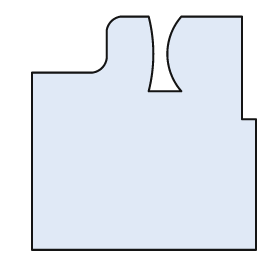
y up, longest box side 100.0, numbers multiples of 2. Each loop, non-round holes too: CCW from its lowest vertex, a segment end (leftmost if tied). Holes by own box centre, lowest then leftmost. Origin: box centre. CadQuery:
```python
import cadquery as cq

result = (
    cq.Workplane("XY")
    .moveTo(-48.0, -50.0)
    .lineTo(48.0, -50.0)
    .lineTo(48.0, 6.0)
    .lineTo(42.0, 6.0)
    .lineTo(42.0, 50.0)
    .lineTo(16.0, 50.0)
    .threePointArc((10.0, 34.0), (16.0, 18.0))
    .lineTo(2.0, 18.0)
    .threePointArc((4.0, 34.0), (2.0, 50.0))
    .lineTo(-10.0, 50.0)
    .threePointArc((-14.0, 48.0), (-16.0, 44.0))
    .lineTo(-16.0, 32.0)
    .threePointArc((-18.0, 28.0), (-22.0, 26.0))
    .lineTo(-48.0, 26.0)
    .close()
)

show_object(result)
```